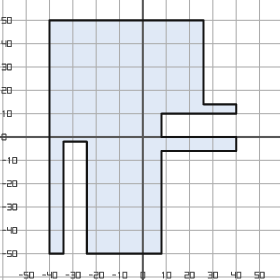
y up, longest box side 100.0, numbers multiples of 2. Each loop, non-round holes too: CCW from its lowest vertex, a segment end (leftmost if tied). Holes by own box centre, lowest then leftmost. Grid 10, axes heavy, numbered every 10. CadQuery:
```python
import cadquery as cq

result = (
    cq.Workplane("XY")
    .moveTo(-40.0, -50.0)
    .lineTo(-34.0, -50.0)
    .lineTo(-34.0, -2.0)
    .lineTo(-24.0, -2.0)
    .lineTo(-24.0, -50.0)
    .lineTo(8.0, -50.0)
    .lineTo(8.0, -6.0)
    .lineTo(40.0, -6.0)
    .lineTo(40.0, 0.0)
    .lineTo(8.0, 0.0)
    .lineTo(8.0, 10.0)
    .lineTo(40.0, 10.0)
    .lineTo(40.0, 14.0)
    .lineTo(26.0, 14.0)
    .lineTo(26.0, 50.0)
    .lineTo(-40.0, 50.0)
    .close()
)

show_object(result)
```